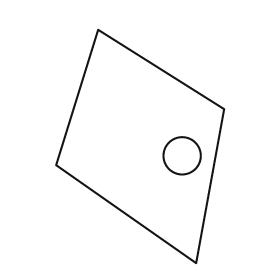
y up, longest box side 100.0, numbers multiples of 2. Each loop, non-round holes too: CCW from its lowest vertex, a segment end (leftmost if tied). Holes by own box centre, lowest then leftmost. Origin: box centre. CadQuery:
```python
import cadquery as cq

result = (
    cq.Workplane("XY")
    .moveTo(24.0, -50.0)
    .lineTo(36.0, 16.0)
    .lineTo(-18.0, 50.0)
    .lineTo(-36.0, -8.0)
    .close()
    .moveTo(18.0, -4.0)
    .circle(8.0)
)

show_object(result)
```